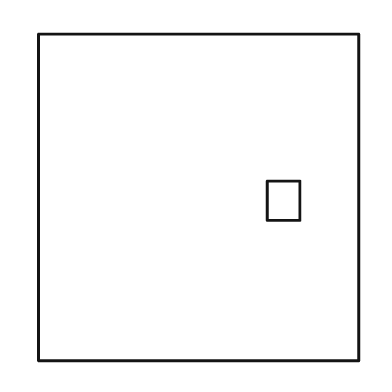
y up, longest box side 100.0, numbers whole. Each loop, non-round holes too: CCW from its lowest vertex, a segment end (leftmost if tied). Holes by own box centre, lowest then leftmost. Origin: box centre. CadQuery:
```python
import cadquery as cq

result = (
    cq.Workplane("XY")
    .moveTo(-49.0, -50.0)
    .lineTo(49.0, -50.0)
    .lineTo(49.0, 50.0)
    .lineTo(-49.0, 50.0)
    .close()
    .moveTo(21.0, -7.0)
    .lineTo(31.0, -7.0)
    .lineTo(31.0, 5.0)
    .lineTo(21.0, 5.0)
    .close()
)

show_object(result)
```